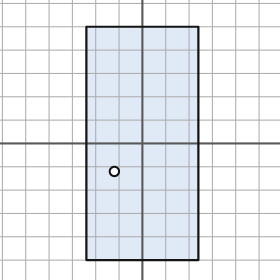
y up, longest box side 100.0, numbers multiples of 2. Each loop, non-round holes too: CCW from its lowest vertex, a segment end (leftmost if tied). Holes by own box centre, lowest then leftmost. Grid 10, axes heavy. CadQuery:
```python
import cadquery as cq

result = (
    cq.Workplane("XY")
    .moveTo(-24.0, -50.0)
    .lineTo(24.0, -50.0)
    .lineTo(24.0, 50.0)
    .lineTo(-24.0, 50.0)
    .close()
    .moveTo(-12.0, -12.0)
    .circle(2.0)
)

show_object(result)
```